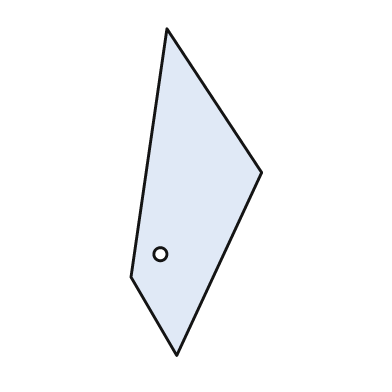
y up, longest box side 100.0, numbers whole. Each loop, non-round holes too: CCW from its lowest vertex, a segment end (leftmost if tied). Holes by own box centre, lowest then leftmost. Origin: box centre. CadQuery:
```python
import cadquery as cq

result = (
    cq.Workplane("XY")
    .moveTo(-6.0, -50.0)
    .lineTo(20.0, 6.0)
    .lineTo(-9.0, 50.0)
    .lineTo(-20.0, -26.0)
    .close()
    .moveTo(-11.0, -19.0)
    .circle(2.0)
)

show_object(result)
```